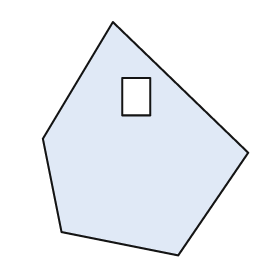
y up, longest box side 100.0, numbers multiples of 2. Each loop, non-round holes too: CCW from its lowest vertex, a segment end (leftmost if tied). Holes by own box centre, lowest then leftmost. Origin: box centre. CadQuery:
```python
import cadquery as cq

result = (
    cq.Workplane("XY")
    .moveTo(14.0, -50.0)
    .lineTo(44.0, -6.0)
    .lineTo(-14.0, 50.0)
    .lineTo(-44.0, 0.0)
    .lineTo(-36.0, -40.0)
    .close()
    .moveTo(-10.0, 10.0)
    .lineTo(2.0, 10.0)
    .lineTo(2.0, 26.0)
    .lineTo(-10.0, 26.0)
    .close()
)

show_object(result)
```